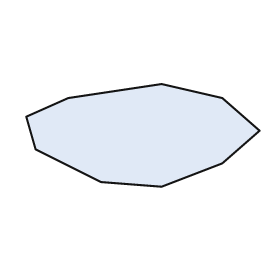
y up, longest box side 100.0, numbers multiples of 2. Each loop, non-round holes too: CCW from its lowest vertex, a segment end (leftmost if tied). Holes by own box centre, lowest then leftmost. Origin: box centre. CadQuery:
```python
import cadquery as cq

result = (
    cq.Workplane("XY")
    .moveTo(8.0, -22.0)
    .lineTo(34.0, -12.0)
    .lineTo(50.0, 2.0)
    .lineTo(34.0, 16.0)
    .lineTo(8.0, 22.0)
    .lineTo(-32.0, 16.0)
    .lineTo(-50.0, 8.0)
    .lineTo(-46.0, -6.0)
    .lineTo(-18.0, -20.0)
    .close()
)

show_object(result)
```